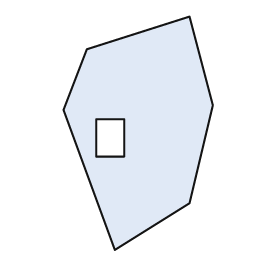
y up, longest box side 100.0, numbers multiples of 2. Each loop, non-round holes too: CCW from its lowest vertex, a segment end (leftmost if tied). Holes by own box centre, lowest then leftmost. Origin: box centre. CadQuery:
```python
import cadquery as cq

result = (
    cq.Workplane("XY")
    .moveTo(-10.0, -50.0)
    .lineTo(22.0, -30.0)
    .lineTo(32.0, 12.0)
    .lineTo(22.0, 50.0)
    .lineTo(-22.0, 36.0)
    .lineTo(-32.0, 10.0)
    .close()
    .moveTo(-18.0, -10.0)
    .lineTo(-6.0, -10.0)
    .lineTo(-6.0, 6.0)
    .lineTo(-18.0, 6.0)
    .close()
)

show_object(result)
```